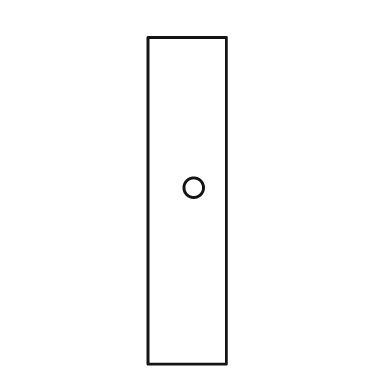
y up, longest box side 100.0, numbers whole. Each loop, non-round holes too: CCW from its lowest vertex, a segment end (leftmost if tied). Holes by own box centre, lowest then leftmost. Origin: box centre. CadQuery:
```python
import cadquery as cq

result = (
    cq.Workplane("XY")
    .moveTo(-12.0, -50.0)
    .lineTo(12.0, -50.0)
    .lineTo(12.0, 50.0)
    .lineTo(-12.0, 50.0)
    .close()
    .moveTo(2.0, 4.0)
    .circle(3.0)
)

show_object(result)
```